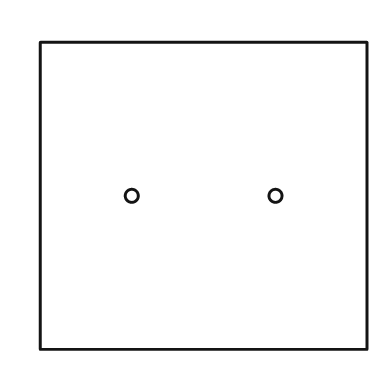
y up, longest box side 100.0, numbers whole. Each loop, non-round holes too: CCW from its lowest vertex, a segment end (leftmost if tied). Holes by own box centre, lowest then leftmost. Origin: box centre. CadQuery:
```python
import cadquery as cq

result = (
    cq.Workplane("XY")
    .moveTo(-50.0, -47.0)
    .lineTo(50.0, -47.0)
    .lineTo(50.0, 47.0)
    .lineTo(-50.0, 47.0)
    .close()
    .moveTo(-22.0, 0.0)
    .circle(2.0)
    .moveTo(22.0, 0.0)
    .circle(2.0)
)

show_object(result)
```